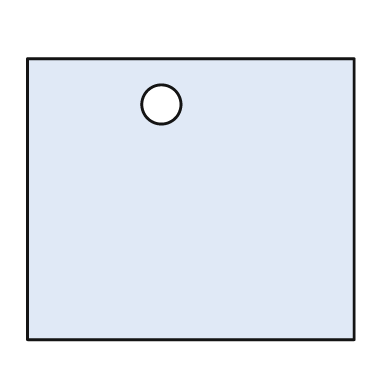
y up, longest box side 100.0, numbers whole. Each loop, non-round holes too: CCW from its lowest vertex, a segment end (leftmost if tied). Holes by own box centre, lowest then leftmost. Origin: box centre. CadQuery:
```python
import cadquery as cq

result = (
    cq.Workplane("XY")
    .moveTo(-50.0, -43.0)
    .lineTo(50.0, -43.0)
    .lineTo(50.0, 43.0)
    .lineTo(-50.0, 43.0)
    .close()
    .moveTo(-9.0, 29.0)
    .circle(6.0)
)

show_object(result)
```